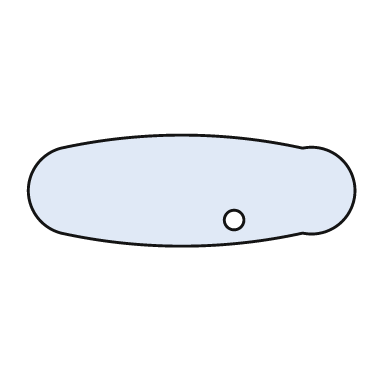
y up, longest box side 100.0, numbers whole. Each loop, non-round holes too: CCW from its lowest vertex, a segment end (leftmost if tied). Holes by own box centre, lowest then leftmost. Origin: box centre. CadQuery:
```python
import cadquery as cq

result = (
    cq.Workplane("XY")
    .moveTo(-40.0, -13.0)
    .threePointArc((-3.0, -17.0), (34.0, -13.0))
    .threePointArc((50.0, 0.0), (34.0, 13.0))
    .threePointArc((-3.0, 17.0), (-40.0, 13.0))
    .threePointArc((-50.0, 0.0), (-40.0, -13.0))
    .close()
    .moveTo(13.0, -9.0)
    .circle(3.0)
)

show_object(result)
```